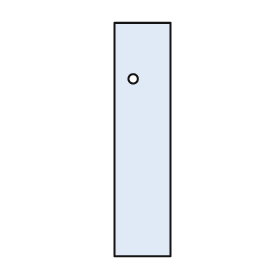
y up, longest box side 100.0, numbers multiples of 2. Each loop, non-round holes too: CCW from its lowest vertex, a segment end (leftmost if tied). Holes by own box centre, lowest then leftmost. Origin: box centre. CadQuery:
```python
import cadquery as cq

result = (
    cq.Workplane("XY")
    .moveTo(-12.0, -50.0)
    .lineTo(12.0, -50.0)
    .lineTo(12.0, 50.0)
    .lineTo(-12.0, 50.0)
    .close()
    .moveTo(-4.0, 26.0)
    .circle(2.0)
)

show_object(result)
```